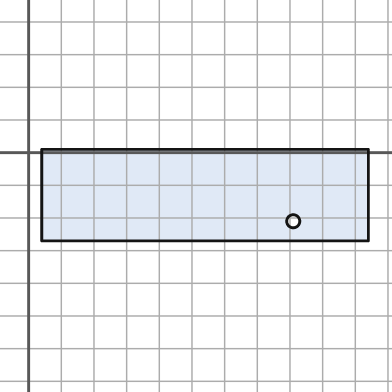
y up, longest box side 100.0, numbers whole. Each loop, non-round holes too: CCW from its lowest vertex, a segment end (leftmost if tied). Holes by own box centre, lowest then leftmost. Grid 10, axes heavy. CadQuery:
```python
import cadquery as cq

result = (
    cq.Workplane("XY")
    .moveTo(4.0, -27.0)
    .lineTo(104.0, -27.0)
    .lineTo(104.0, 1.0)
    .lineTo(4.0, 1.0)
    .close()
    .moveTo(81.0, -21.0)
    .circle(2.0)
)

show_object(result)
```